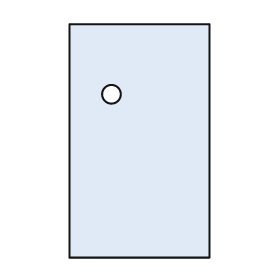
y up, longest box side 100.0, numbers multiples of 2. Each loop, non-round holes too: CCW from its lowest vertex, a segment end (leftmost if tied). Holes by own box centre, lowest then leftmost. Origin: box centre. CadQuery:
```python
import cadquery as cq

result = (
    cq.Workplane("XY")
    .moveTo(-30.0, -50.0)
    .lineTo(30.0, -50.0)
    .lineTo(30.0, 50.0)
    .lineTo(-30.0, 50.0)
    .close()
    .moveTo(-12.0, 20.0)
    .circle(4.0)
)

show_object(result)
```